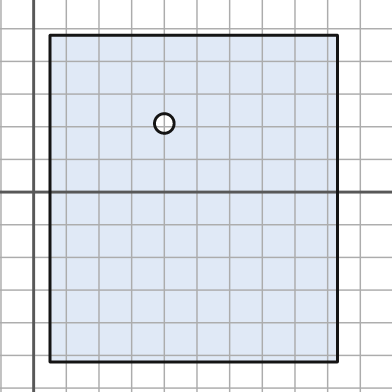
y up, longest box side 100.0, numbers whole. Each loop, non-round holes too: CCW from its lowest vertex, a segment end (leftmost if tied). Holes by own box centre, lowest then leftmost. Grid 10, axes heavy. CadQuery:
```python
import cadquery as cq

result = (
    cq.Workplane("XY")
    .moveTo(5.0, -52.0)
    .lineTo(93.0, -52.0)
    .lineTo(93.0, 48.0)
    .lineTo(5.0, 48.0)
    .close()
    .moveTo(40.0, 21.0)
    .circle(3.0)
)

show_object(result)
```